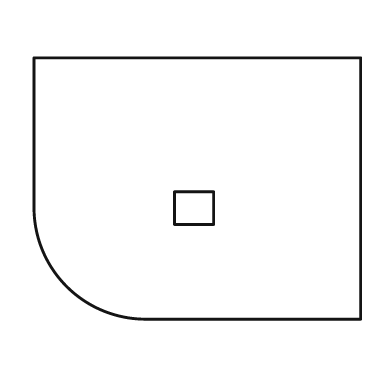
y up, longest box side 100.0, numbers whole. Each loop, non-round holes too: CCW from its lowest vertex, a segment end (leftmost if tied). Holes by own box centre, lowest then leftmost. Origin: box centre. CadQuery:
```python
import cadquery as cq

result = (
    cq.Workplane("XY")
    .moveTo(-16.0, -40.0)
    .lineTo(50.0, -40.0)
    .lineTo(50.0, 40.0)
    .lineTo(-50.0, 40.0)
    .lineTo(-50.0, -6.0)
    .threePointArc((-40.0, -30.0), (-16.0, -40.0))
    .close()
    .moveTo(-7.0, -11.0)
    .lineTo(5.0, -11.0)
    .lineTo(5.0, -1.0)
    .lineTo(-7.0, -1.0)
    .close()
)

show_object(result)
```